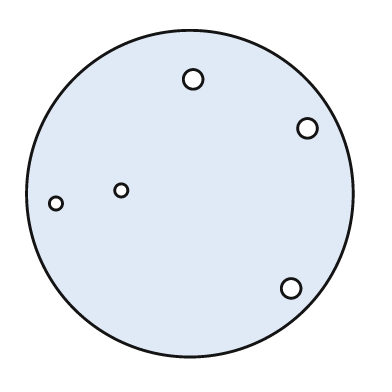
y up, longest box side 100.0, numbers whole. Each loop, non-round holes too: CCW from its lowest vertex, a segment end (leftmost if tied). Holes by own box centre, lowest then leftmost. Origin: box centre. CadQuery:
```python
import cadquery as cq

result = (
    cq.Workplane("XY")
    .moveTo(0.0, 0.0)
    .circle(50.0)
    .moveTo(31.0, -29.0)
    .circle(3.0)
    .moveTo(-41.0, -3.0)
    .circle(2.0)
    .moveTo(-21.0, 1.0)
    .circle(2.0)
    .moveTo(36.0, 20.0)
    .circle(3.0)
    .moveTo(1.0, 35.0)
    .circle(3.0)
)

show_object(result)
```